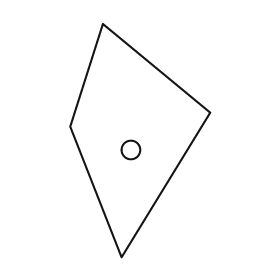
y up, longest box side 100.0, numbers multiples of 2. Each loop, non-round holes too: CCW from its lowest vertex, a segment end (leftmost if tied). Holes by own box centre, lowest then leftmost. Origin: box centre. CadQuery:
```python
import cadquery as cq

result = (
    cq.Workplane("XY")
    .moveTo(-8.0, -50.0)
    .lineTo(30.0, 12.0)
    .lineTo(-16.0, 50.0)
    .lineTo(-30.0, 6.0)
    .close()
    .moveTo(-4.0, -4.0)
    .circle(4.0)
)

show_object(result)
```